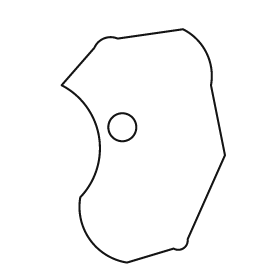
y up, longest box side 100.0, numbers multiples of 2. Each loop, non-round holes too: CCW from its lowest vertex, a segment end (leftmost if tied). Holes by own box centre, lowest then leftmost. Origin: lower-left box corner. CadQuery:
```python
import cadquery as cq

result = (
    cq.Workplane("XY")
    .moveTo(28.0, 0.0)
    .lineTo(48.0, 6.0)
    .threePointArc((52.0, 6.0), (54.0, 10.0))
    .lineTo(70.0, 46.0)
    .lineTo(64.0, 76.0)
    .threePointArc((62.0, 90.0), (52.0, 100.0))
    .lineTo(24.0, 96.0)
    .threePointArc((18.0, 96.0), (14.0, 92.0))
    .lineTo(0.0, 76.0)
    .threePointArc((16.0, 54.0), (8.0, 28.0))
    .threePointArc((12.0, 10.0), (28.0, 0.0))
    .close()
    .moveTo(26.0, 58.0)
    .circle(6.0)
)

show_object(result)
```